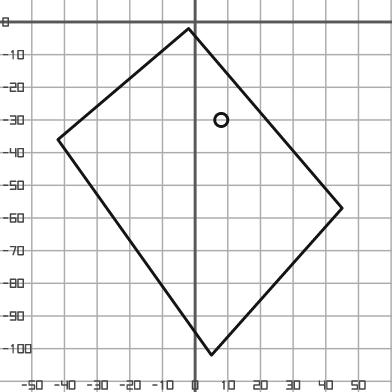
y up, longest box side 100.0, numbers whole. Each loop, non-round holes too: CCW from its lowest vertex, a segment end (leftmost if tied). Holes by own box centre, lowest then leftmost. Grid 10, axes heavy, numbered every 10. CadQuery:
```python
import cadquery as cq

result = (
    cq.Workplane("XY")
    .moveTo(5.0, -102.0)
    .lineTo(45.0, -57.0)
    .lineTo(-2.0, -2.0)
    .lineTo(-42.0, -36.0)
    .close()
    .moveTo(8.0, -30.0)
    .circle(2.0)
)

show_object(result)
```